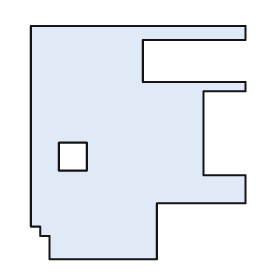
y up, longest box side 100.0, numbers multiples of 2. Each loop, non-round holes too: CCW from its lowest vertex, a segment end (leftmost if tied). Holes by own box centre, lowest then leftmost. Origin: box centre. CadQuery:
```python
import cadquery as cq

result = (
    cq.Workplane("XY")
    .moveTo(-38.0, -50.0)
    .lineTo(8.0, -50.0)
    .lineTo(8.0, -26.0)
    .lineTo(46.0, -26.0)
    .lineTo(46.0, -14.0)
    .lineTo(28.0, -14.0)
    .lineTo(28.0, 22.0)
    .lineTo(46.0, 22.0)
    .lineTo(46.0, 26.0)
    .lineTo(2.0, 26.0)
    .lineTo(2.0, 44.0)
    .lineTo(46.0, 44.0)
    .lineTo(46.0, 50.0)
    .lineTo(-46.0, 50.0)
    .lineTo(-46.0, -36.0)
    .lineTo(-42.0, -36.0)
    .lineTo(-42.0, -40.0)
    .lineTo(-38.0, -40.0)
    .close()
    .moveTo(-34.0, -12.0)
    .lineTo(-22.0, -12.0)
    .lineTo(-22.0, 0.0)
    .lineTo(-34.0, 0.0)
    .close()
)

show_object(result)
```